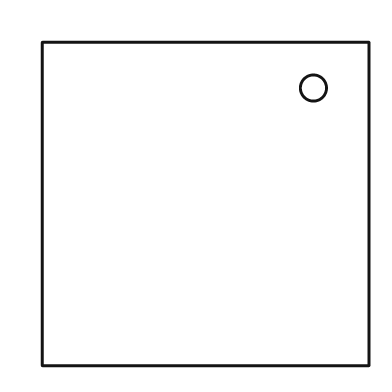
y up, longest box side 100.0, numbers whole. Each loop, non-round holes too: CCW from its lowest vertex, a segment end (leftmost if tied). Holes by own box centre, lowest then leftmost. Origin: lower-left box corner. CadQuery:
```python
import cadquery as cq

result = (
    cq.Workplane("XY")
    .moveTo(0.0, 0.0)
    .lineTo(100.0, 0.0)
    .lineTo(100.0, 99.0)
    .lineTo(0.0, 99.0)
    .close()
    .moveTo(83.0, 85.0)
    .circle(4.0)
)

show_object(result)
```